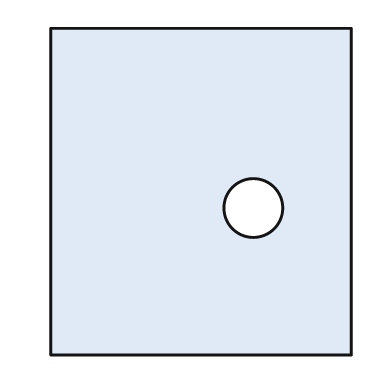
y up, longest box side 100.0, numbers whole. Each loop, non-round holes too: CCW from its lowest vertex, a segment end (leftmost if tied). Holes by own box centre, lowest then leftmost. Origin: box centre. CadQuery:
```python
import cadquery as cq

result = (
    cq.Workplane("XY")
    .moveTo(-46.0, -50.0)
    .lineTo(46.0, -50.0)
    .lineTo(46.0, 50.0)
    .lineTo(-46.0, 50.0)
    .close()
    .moveTo(16.0, -5.0)
    .circle(9.0)
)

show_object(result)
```